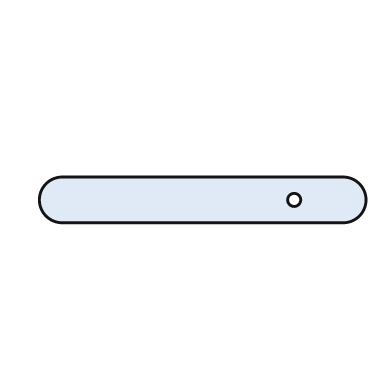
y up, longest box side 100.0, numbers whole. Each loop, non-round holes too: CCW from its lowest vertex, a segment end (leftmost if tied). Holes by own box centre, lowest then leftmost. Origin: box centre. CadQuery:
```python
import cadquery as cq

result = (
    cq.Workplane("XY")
    .moveTo(-43.0, -7.0)
    .lineTo(43.0, -7.0)
    .threePointArc((50.0, 0.0), (43.0, 7.0))
    .lineTo(-43.0, 7.0)
    .threePointArc((-50.0, 0.0), (-43.0, -7.0))
    .close()
    .moveTo(28.0, 0.0)
    .circle(2.0)
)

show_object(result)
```